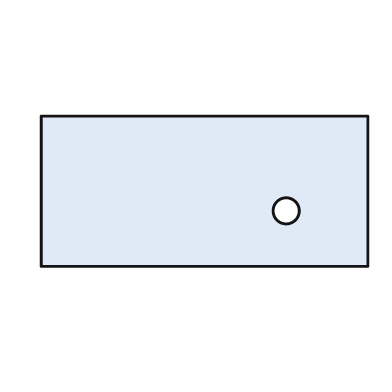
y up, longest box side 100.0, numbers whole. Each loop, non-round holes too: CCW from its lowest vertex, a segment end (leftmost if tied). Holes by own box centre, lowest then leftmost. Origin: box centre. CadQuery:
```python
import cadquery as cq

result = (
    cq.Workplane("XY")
    .moveTo(-50.0, -23.0)
    .lineTo(50.0, -23.0)
    .lineTo(50.0, 23.0)
    .lineTo(-50.0, 23.0)
    .close()
    .moveTo(25.0, -6.0)
    .circle(4.0)
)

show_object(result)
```